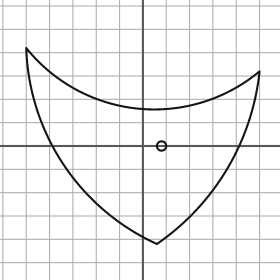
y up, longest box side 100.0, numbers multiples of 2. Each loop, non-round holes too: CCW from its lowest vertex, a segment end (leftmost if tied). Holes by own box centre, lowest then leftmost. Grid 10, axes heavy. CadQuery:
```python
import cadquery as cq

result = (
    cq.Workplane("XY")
    .moveTo(6.0, -42.0)
    .threePointArc((36.0, -10.0), (50.0, 32.0))
    .threePointArc((-2.0, 16.0), (-50.0, 42.0))
    .threePointArc((-34.0, -8.0), (6.0, -42.0))
    .close()
    .moveTo(8.0, 0.0)
    .circle(2.0)
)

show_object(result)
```